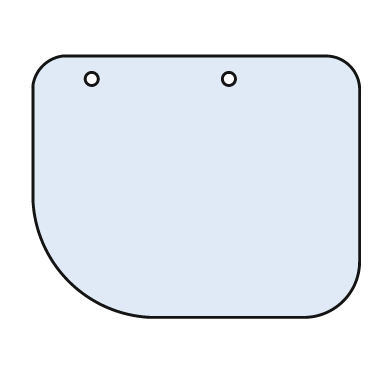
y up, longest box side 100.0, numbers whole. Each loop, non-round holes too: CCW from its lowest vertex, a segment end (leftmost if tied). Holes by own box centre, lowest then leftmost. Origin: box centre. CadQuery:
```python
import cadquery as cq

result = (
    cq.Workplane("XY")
    .moveTo(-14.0, -40.0)
    .lineTo(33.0, -40.0)
    .threePointArc((45.0, -35.0), (50.0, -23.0))
    .lineTo(50.0, 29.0)
    .threePointArc((47.0, 37.0), (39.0, 40.0))
    .lineTo(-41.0, 40.0)
    .threePointArc((-47.0, 37.0), (-50.0, 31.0))
    .lineTo(-50.0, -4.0)
    .threePointArc((-39.0, -29.0), (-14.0, -40.0))
    .close()
    .moveTo(-32.0, 33.0)
    .circle(2.0)
    .moveTo(10.0, 33.0)
    .circle(2.0)
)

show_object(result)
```